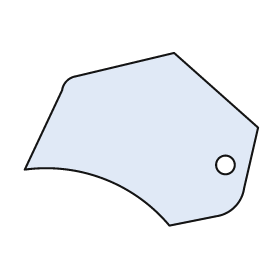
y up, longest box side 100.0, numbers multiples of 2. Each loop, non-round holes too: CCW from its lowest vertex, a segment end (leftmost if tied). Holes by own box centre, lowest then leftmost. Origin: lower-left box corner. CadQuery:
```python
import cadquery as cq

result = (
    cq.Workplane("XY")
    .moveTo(62.0, 0.0)
    .lineTo(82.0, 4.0)
    .threePointArc((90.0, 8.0), (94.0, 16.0))
    .lineTo(100.0, 42.0)
    .lineTo(64.0, 74.0)
    .lineTo(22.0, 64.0)
    .threePointArc((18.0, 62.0), (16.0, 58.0))
    .lineTo(0.0, 24.0)
    .threePointArc((34.0, 20.0), (62.0, 0.0))
    .close()
    .moveTo(86.0, 26.0)
    .circle(4.0)
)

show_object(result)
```